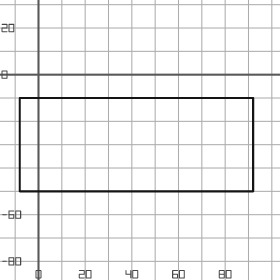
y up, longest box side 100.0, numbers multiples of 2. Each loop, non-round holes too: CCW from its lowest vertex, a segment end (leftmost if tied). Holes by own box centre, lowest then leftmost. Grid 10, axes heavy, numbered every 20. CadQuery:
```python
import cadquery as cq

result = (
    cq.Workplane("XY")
    .moveTo(-8.0, -50.0)
    .lineTo(92.0, -50.0)
    .lineTo(92.0, -10.0)
    .lineTo(-8.0, -10.0)
    .close()
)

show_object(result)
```